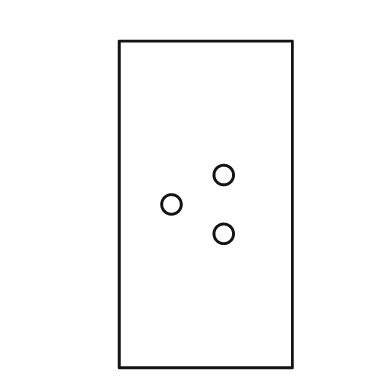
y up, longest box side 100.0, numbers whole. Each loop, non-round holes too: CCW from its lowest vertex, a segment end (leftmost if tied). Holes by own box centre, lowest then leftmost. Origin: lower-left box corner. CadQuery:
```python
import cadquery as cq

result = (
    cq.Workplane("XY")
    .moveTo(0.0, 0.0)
    .lineTo(53.0, 0.0)
    .lineTo(53.0, 100.0)
    .lineTo(0.0, 100.0)
    .close()
    .moveTo(32.0, 41.0)
    .circle(3.0)
    .moveTo(16.0, 50.0)
    .circle(3.0)
    .moveTo(32.0, 59.0)
    .circle(3.0)
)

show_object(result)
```